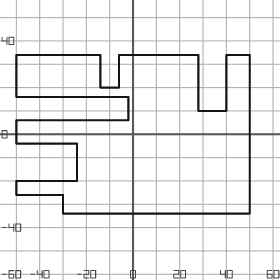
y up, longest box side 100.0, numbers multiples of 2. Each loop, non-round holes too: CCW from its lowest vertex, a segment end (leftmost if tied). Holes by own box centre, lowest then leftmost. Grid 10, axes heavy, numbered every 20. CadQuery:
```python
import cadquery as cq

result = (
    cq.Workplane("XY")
    .moveTo(-30.0, -34.0)
    .lineTo(50.0, -34.0)
    .lineTo(50.0, 34.0)
    .lineTo(40.0, 34.0)
    .lineTo(40.0, 10.0)
    .lineTo(28.0, 10.0)
    .lineTo(28.0, 34.0)
    .lineTo(-6.0, 34.0)
    .lineTo(-6.0, 20.0)
    .lineTo(-14.0, 20.0)
    .lineTo(-14.0, 34.0)
    .lineTo(-50.0, 34.0)
    .lineTo(-50.0, 16.0)
    .lineTo(-2.0, 16.0)
    .lineTo(-2.0, 6.0)
    .lineTo(-50.0, 6.0)
    .lineTo(-50.0, -4.0)
    .lineTo(-24.0, -4.0)
    .lineTo(-24.0, -20.0)
    .lineTo(-50.0, -20.0)
    .lineTo(-50.0, -26.0)
    .lineTo(-30.0, -26.0)
    .close()
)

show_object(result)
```